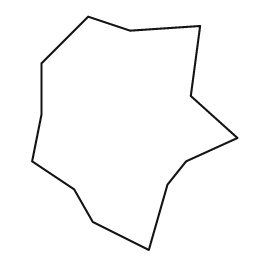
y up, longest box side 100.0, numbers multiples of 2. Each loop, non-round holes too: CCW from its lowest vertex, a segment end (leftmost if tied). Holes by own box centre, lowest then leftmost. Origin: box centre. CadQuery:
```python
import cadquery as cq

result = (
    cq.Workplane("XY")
    .moveTo(6.0, -50.0)
    .lineTo(14.0, -22.0)
    .lineTo(22.0, -12.0)
    .lineTo(44.0, -2.0)
    .lineTo(24.0, 16.0)
    .lineTo(28.0, 46.0)
    .lineTo(-2.0, 44.0)
    .lineTo(-20.0, 50.0)
    .lineTo(-40.0, 30.0)
    .lineTo(-40.0, 8.0)
    .lineTo(-44.0, -12.0)
    .lineTo(-26.0, -24.0)
    .lineTo(-18.0, -38.0)
    .close()
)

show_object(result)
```